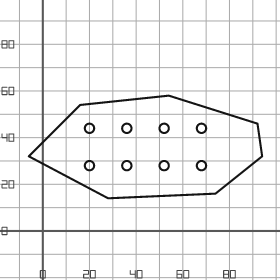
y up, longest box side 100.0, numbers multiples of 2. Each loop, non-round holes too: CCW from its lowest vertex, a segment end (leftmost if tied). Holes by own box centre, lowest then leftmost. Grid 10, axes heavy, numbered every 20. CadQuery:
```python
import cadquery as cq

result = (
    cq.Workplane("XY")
    .moveTo(28.0, 14.0)
    .lineTo(74.0, 16.0)
    .lineTo(94.0, 32.0)
    .lineTo(92.0, 46.0)
    .lineTo(54.0, 58.0)
    .lineTo(16.0, 54.0)
    .lineTo(-6.0, 32.0)
    .close()
    .moveTo(20.0, 28.0)
    .circle(2.0)
    .moveTo(36.0, 28.0)
    .circle(2.0)
    .moveTo(52.0, 28.0)
    .circle(2.0)
    .moveTo(68.0, 28.0)
    .circle(2.0)
    .moveTo(20.0, 44.0)
    .circle(2.0)
    .moveTo(36.0, 44.0)
    .circle(2.0)
    .moveTo(52.0, 44.0)
    .circle(2.0)
    .moveTo(68.0, 44.0)
    .circle(2.0)
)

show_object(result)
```